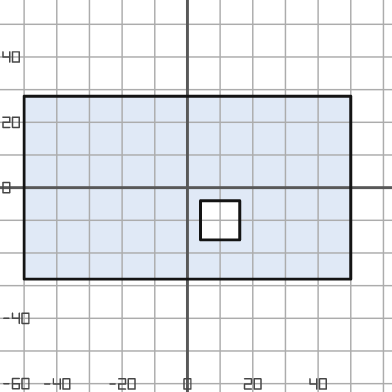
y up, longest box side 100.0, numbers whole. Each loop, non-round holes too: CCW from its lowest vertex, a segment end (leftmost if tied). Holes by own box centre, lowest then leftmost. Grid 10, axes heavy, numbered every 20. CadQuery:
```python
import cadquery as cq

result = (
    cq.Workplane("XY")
    .moveTo(-50.0, -28.0)
    .lineTo(50.0, -28.0)
    .lineTo(50.0, 28.0)
    .lineTo(-50.0, 28.0)
    .close()
    .moveTo(4.0, -16.0)
    .lineTo(16.0, -16.0)
    .lineTo(16.0, -4.0)
    .lineTo(4.0, -4.0)
    .close()
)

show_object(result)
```